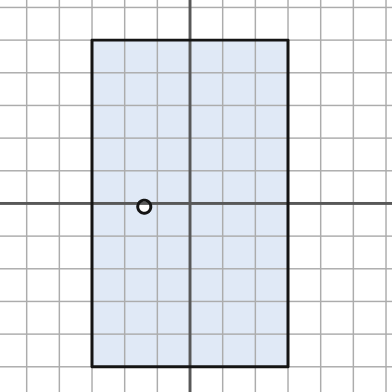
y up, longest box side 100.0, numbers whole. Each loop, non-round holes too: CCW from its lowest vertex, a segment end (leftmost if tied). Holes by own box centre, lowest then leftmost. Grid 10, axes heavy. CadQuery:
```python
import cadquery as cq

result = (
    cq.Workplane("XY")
    .moveTo(-30.0, -50.0)
    .lineTo(30.0, -50.0)
    .lineTo(30.0, 50.0)
    .lineTo(-30.0, 50.0)
    .close()
    .moveTo(-14.0, -1.0)
    .circle(2.0)
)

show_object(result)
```